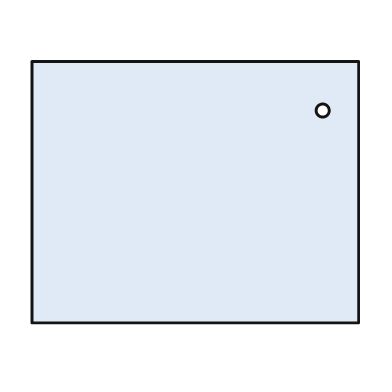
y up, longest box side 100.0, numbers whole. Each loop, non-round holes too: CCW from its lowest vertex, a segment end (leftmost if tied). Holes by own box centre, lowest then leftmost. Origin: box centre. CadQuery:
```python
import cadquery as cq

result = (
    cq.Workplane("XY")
    .moveTo(-50.0, -40.0)
    .lineTo(50.0, -40.0)
    .lineTo(50.0, 40.0)
    .lineTo(-50.0, 40.0)
    .close()
    .moveTo(39.0, 25.0)
    .circle(2.0)
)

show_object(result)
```